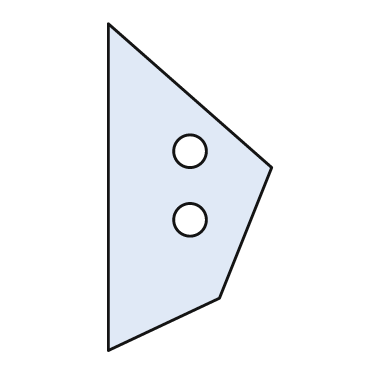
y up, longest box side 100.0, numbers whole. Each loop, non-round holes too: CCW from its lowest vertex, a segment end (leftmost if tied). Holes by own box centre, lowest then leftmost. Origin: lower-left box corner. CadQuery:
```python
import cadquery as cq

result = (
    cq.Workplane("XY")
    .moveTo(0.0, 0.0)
    .lineTo(34.0, 16.0)
    .lineTo(50.0, 56.0)
    .lineTo(0.0, 100.0)
    .close()
    .moveTo(25.0, 40.0)
    .circle(5.0)
    .moveTo(25.0, 61.0)
    .circle(5.0)
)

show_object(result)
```